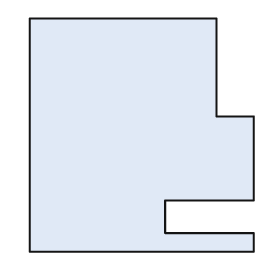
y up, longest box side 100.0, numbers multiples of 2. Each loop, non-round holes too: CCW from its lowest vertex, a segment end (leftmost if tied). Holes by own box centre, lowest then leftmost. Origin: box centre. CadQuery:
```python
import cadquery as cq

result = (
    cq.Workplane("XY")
    .moveTo(-48.0, -50.0)
    .lineTo(48.0, -50.0)
    .lineTo(48.0, -42.0)
    .lineTo(10.0, -42.0)
    .lineTo(10.0, -28.0)
    .lineTo(48.0, -28.0)
    .lineTo(48.0, 8.0)
    .lineTo(32.0, 8.0)
    .lineTo(32.0, 50.0)
    .lineTo(-48.0, 50.0)
    .close()
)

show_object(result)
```